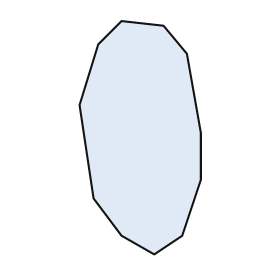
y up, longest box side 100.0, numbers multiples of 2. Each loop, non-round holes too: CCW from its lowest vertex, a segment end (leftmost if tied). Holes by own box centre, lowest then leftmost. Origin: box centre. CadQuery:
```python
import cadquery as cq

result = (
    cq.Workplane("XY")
    .moveTo(6.0, -50.0)
    .lineTo(18.0, -42.0)
    .lineTo(26.0, -18.0)
    .lineTo(26.0, 2.0)
    .lineTo(20.0, 36.0)
    .lineTo(10.0, 48.0)
    .lineTo(-8.0, 50.0)
    .lineTo(-18.0, 40.0)
    .lineTo(-26.0, 14.0)
    .lineTo(-20.0, -26.0)
    .lineTo(-8.0, -42.0)
    .close()
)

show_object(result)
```